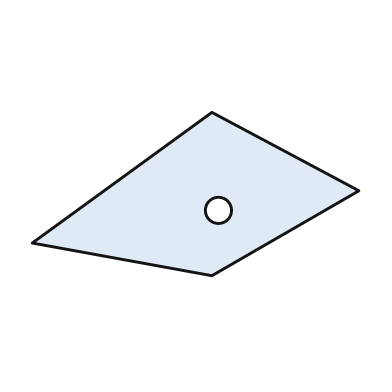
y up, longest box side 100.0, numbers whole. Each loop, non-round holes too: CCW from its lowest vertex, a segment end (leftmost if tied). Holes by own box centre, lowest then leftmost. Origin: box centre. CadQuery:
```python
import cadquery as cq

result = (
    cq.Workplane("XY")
    .moveTo(5.0, -25.0)
    .lineTo(50.0, 1.0)
    .lineTo(5.0, 25.0)
    .lineTo(-50.0, -15.0)
    .close()
    .moveTo(7.0, -5.0)
    .circle(4.0)
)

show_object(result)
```